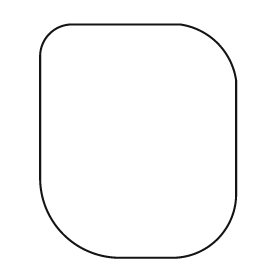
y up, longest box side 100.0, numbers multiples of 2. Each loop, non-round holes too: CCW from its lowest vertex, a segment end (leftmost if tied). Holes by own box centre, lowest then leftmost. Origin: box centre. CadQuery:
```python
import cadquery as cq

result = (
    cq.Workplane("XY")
    .moveTo(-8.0, -50.0)
    .lineTo(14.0, -50.0)
    .threePointArc((34.0, -42.0), (42.0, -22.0))
    .lineTo(42.0, 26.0)
    .threePointArc((34.0, 42.0), (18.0, 50.0))
    .lineTo(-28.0, 50.0)
    .threePointArc((-38.0, 46.0), (-42.0, 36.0))
    .lineTo(-42.0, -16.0)
    .threePointArc((-32.0, -40.0), (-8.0, -50.0))
    .close()
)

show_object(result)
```